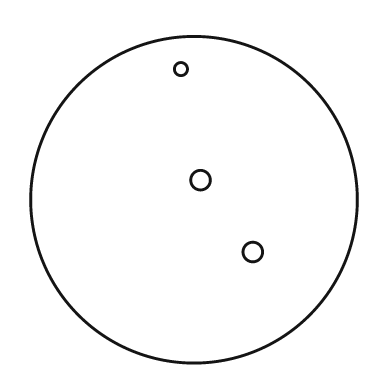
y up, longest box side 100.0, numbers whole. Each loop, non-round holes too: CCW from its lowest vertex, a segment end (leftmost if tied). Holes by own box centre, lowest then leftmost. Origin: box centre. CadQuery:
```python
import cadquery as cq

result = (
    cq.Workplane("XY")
    .moveTo(0.0, 0.0)
    .circle(50.0)
    .moveTo(18.0, -16.0)
    .circle(3.0)
    .moveTo(2.0, 6.0)
    .circle(3.0)
    .moveTo(-4.0, 40.0)
    .circle(2.0)
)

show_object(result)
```